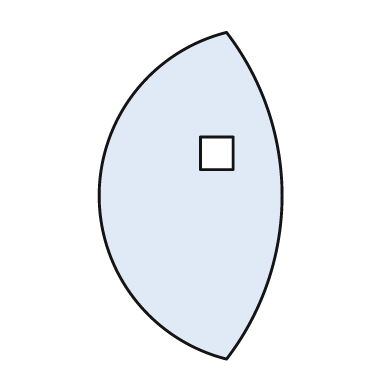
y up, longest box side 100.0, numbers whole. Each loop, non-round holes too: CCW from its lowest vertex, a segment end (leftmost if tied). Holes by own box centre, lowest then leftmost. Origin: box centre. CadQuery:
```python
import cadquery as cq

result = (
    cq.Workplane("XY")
    .moveTo(11.0, -50.0)
    .threePointArc((28.0, 0.0), (11.0, 50.0))
    .threePointArc((-28.0, 0.0), (11.0, -50.0))
    .close()
    .moveTo(3.0, 8.0)
    .lineTo(13.0, 8.0)
    .lineTo(13.0, 18.0)
    .lineTo(3.0, 18.0)
    .close()
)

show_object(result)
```